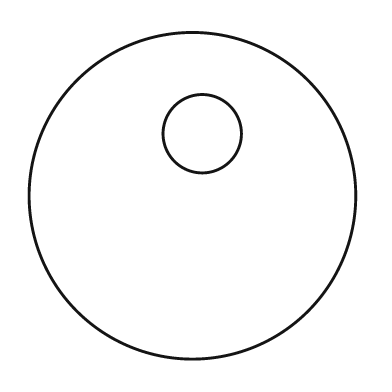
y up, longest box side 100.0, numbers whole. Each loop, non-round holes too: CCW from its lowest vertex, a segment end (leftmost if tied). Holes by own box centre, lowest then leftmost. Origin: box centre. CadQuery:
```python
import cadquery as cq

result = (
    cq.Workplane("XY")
    .moveTo(0.0, 0.0)
    .circle(50.0)
    .moveTo(3.0, 19.0)
    .circle(12.0)
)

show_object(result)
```